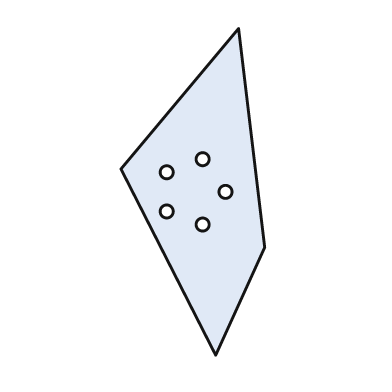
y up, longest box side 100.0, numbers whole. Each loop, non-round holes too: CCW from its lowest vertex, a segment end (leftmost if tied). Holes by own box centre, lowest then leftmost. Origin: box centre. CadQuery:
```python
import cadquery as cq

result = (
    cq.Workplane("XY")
    .moveTo(7.0, -50.0)
    .lineTo(22.0, -17.0)
    .lineTo(14.0, 50.0)
    .lineTo(-22.0, 7.0)
    .close()
    .moveTo(3.0, -10.0)
    .circle(2.0)
    .moveTo(-8.0, -6.0)
    .circle(2.0)
    .moveTo(10.0, 0.0)
    .circle(2.0)
    .moveTo(-8.0, 6.0)
    .circle(2.0)
    .moveTo(3.0, 10.0)
    .circle(2.0)
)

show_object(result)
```